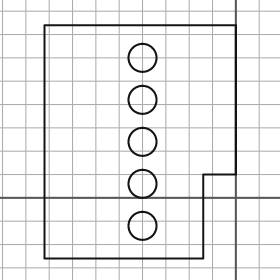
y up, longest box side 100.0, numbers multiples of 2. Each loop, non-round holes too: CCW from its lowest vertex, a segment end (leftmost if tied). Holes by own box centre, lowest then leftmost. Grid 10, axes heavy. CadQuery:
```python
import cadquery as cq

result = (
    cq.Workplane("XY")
    .moveTo(-82.0, -26.0)
    .lineTo(-14.0, -26.0)
    .lineTo(-14.0, 10.0)
    .lineTo(0.0, 10.0)
    .lineTo(0.0, 74.0)
    .lineTo(-82.0, 74.0)
    .close()
    .moveTo(-40.0, -12.0)
    .circle(6.0)
    .moveTo(-40.0, 6.0)
    .circle(6.0)
    .moveTo(-40.0, 24.0)
    .circle(6.0)
    .moveTo(-40.0, 42.0)
    .circle(6.0)
    .moveTo(-40.0, 60.0)
    .circle(6.0)
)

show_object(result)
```